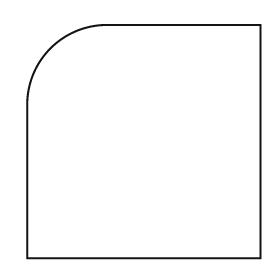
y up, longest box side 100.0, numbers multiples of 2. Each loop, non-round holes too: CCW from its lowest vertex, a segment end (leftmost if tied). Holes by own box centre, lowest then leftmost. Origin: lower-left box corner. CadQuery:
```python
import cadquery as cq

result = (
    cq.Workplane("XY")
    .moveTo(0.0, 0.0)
    .lineTo(100.0, 0.0)
    .lineTo(100.0, 100.0)
    .lineTo(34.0, 100.0)
    .threePointArc((10.0, 90.0), (0.0, 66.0))
    .close()
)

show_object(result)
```